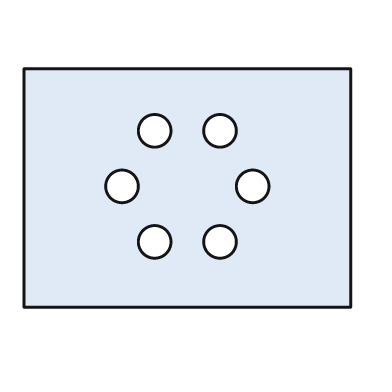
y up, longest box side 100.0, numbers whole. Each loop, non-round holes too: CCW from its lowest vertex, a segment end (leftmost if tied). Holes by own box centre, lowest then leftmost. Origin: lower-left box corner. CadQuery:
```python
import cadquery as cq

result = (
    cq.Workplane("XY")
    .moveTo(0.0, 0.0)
    .lineTo(100.0, 0.0)
    .lineTo(100.0, 73.0)
    .lineTo(0.0, 73.0)
    .close()
    .moveTo(40.0, 20.0)
    .circle(5.0)
    .moveTo(60.0, 20.0)
    .circle(5.0)
    .moveTo(30.0, 37.0)
    .circle(5.0)
    .moveTo(70.0, 37.0)
    .circle(5.0)
    .moveTo(40.0, 54.0)
    .circle(5.0)
    .moveTo(60.0, 54.0)
    .circle(5.0)
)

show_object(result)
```